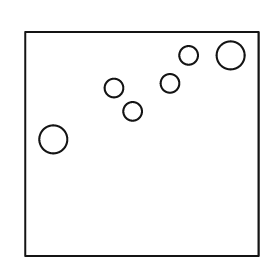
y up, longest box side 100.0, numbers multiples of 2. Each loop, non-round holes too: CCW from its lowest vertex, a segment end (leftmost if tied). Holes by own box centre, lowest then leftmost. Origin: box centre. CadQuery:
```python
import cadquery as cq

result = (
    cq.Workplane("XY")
    .moveTo(-50.0, -48.0)
    .lineTo(50.0, -48.0)
    .lineTo(50.0, 48.0)
    .lineTo(-50.0, 48.0)
    .close()
    .moveTo(-38.0, 2.0)
    .circle(6.0)
    .moveTo(-4.0, 14.0)
    .circle(4.0)
    .moveTo(-12.0, 24.0)
    .circle(4.0)
    .moveTo(12.0, 26.0)
    .circle(4.0)
    .moveTo(20.0, 38.0)
    .circle(4.0)
    .moveTo(38.0, 38.0)
    .circle(6.0)
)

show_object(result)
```